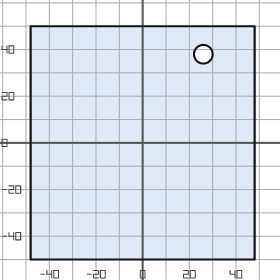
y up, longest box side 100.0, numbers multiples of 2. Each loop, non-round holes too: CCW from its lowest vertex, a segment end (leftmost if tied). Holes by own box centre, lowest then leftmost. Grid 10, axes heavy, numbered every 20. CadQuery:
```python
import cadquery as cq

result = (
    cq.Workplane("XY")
    .moveTo(-48.0, -50.0)
    .lineTo(48.0, -50.0)
    .lineTo(48.0, 50.0)
    .lineTo(-48.0, 50.0)
    .close()
    .moveTo(26.0, 38.0)
    .circle(4.0)
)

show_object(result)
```